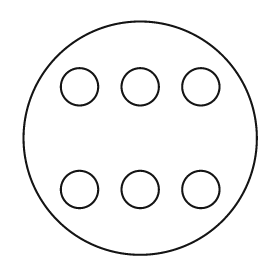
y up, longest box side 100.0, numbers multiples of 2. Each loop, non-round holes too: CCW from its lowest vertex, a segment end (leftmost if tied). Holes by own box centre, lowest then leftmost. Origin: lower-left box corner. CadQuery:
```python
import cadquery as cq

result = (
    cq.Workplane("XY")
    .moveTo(50.0, 50.0)
    .circle(50.0)
    .moveTo(24.0, 28.0)
    .circle(8.0)
    .moveTo(50.0, 28.0)
    .circle(8.0)
    .moveTo(76.0, 28.0)
    .circle(8.0)
    .moveTo(24.0, 72.0)
    .circle(8.0)
    .moveTo(50.0, 72.0)
    .circle(8.0)
    .moveTo(76.0, 72.0)
    .circle(8.0)
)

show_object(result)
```